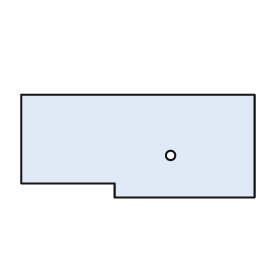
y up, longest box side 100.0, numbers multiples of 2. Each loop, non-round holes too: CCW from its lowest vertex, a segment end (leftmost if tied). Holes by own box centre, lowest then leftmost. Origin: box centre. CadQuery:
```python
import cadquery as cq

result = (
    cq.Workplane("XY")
    .moveTo(-10.0, -22.0)
    .lineTo(50.0, -22.0)
    .lineTo(50.0, 22.0)
    .lineTo(-50.0, 22.0)
    .lineTo(-50.0, -16.0)
    .lineTo(-10.0, -16.0)
    .close()
    .moveTo(14.0, -4.0)
    .circle(2.0)
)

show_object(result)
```